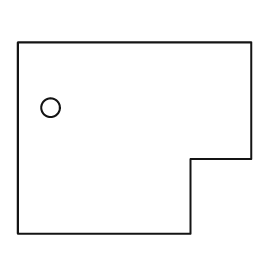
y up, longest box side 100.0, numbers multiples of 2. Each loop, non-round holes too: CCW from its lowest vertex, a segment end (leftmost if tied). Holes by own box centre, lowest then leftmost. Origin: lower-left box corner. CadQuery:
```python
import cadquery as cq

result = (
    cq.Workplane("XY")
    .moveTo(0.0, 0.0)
    .lineTo(74.0, 0.0)
    .lineTo(74.0, 32.0)
    .lineTo(100.0, 32.0)
    .lineTo(100.0, 82.0)
    .lineTo(0.0, 82.0)
    .close()
    .moveTo(14.0, 54.0)
    .circle(4.0)
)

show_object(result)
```